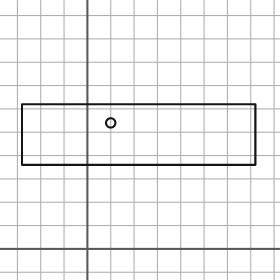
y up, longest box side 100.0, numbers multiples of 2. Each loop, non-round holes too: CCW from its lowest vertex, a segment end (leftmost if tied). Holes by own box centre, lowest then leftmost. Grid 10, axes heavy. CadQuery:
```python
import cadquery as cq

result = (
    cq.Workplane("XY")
    .moveTo(-28.0, 36.0)
    .lineTo(72.0, 36.0)
    .lineTo(72.0, 62.0)
    .lineTo(-28.0, 62.0)
    .close()
    .moveTo(10.0, 54.0)
    .circle(2.0)
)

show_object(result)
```